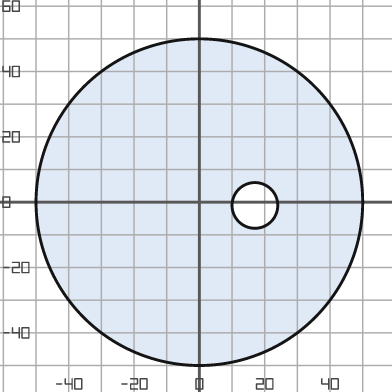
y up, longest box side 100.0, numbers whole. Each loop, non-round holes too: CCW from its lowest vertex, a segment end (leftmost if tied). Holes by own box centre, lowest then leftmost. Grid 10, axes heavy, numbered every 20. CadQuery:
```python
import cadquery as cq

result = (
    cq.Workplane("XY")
    .moveTo(0.0, 0.0)
    .circle(50.0)
    .moveTo(17.0, -1.0)
    .circle(7.0)
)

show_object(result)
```